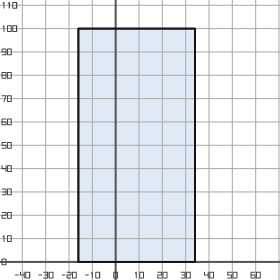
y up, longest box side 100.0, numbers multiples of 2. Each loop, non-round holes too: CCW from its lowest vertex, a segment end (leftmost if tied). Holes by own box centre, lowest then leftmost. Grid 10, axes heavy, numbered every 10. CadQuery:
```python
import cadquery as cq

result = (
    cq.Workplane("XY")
    .moveTo(-16.0, 0.0)
    .lineTo(34.0, 0.0)
    .lineTo(34.0, 100.0)
    .lineTo(-16.0, 100.0)
    .close()
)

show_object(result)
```